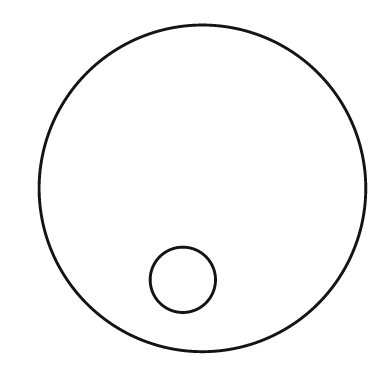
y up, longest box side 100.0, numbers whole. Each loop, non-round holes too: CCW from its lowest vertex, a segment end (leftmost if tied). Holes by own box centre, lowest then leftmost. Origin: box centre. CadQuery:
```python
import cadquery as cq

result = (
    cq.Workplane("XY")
    .moveTo(0.0, 0.0)
    .circle(50.0)
    .moveTo(-6.0, -28.0)
    .circle(10.0)
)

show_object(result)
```